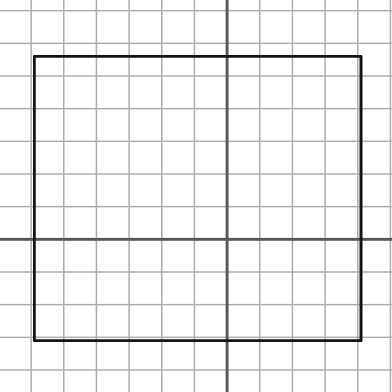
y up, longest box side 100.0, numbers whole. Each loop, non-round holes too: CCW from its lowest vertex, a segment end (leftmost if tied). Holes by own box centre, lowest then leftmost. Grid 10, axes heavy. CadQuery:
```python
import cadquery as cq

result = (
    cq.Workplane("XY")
    .moveTo(-59.0, -31.0)
    .lineTo(41.0, -31.0)
    .lineTo(41.0, 56.0)
    .lineTo(-59.0, 56.0)
    .close()
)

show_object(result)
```